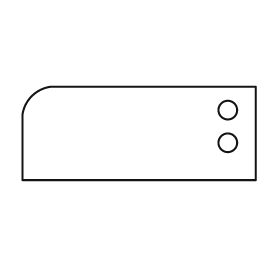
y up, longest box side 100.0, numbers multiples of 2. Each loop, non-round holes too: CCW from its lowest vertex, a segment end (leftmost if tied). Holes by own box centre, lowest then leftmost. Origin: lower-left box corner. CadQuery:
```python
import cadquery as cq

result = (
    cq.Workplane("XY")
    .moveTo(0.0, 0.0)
    .lineTo(100.0, 0.0)
    .lineTo(100.0, 40.0)
    .lineTo(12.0, 40.0)
    .threePointArc((4.0, 36.0), (0.0, 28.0))
    .close()
    .moveTo(88.0, 16.0)
    .circle(4.0)
    .moveTo(88.0, 30.0)
    .circle(4.0)
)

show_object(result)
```